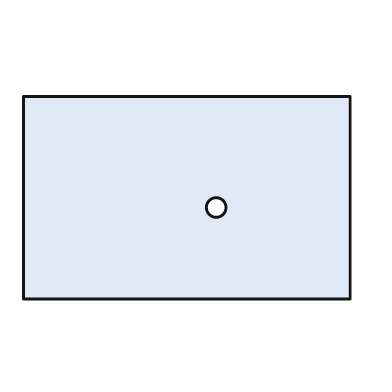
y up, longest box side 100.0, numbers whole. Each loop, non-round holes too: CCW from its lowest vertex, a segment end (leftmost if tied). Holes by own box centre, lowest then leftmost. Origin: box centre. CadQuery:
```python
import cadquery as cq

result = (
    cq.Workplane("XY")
    .moveTo(-50.0, -31.0)
    .lineTo(50.0, -31.0)
    .lineTo(50.0, 31.0)
    .lineTo(-50.0, 31.0)
    .close()
    .moveTo(9.0, -3.0)
    .circle(3.0)
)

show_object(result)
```